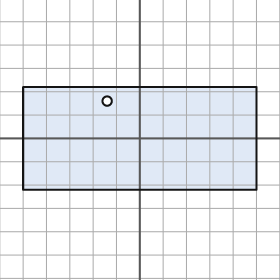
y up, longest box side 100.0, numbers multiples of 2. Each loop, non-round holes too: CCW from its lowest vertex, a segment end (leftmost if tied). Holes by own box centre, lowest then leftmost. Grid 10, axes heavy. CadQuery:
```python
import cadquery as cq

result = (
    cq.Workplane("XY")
    .moveTo(-50.0, -22.0)
    .lineTo(50.0, -22.0)
    .lineTo(50.0, 22.0)
    .lineTo(-50.0, 22.0)
    .close()
    .moveTo(-14.0, 16.0)
    .circle(2.0)
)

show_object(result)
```